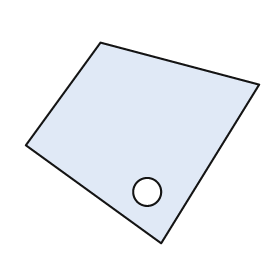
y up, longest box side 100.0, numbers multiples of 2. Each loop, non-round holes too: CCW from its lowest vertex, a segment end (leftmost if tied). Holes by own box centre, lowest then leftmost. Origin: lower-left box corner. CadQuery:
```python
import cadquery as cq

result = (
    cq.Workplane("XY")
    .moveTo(58.0, 0.0)
    .lineTo(100.0, 68.0)
    .lineTo(32.0, 86.0)
    .lineTo(0.0, 42.0)
    .close()
    .moveTo(52.0, 22.0)
    .circle(6.0)
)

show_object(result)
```